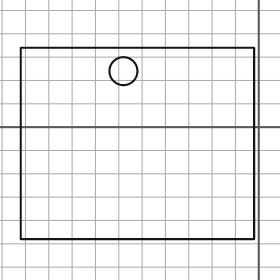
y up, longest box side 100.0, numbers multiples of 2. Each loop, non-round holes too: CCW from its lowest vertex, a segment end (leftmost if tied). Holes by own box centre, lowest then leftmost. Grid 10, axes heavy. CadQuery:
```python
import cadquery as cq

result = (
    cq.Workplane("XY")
    .moveTo(-102.0, -48.0)
    .lineTo(-2.0, -48.0)
    .lineTo(-2.0, 34.0)
    .lineTo(-102.0, 34.0)
    .close()
    .moveTo(-58.0, 24.0)
    .circle(6.0)
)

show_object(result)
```